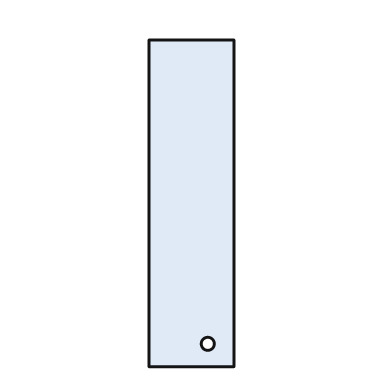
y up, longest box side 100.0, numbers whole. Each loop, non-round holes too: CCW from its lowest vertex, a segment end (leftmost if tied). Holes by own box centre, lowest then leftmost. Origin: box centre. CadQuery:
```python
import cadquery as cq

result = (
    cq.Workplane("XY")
    .moveTo(-13.0, -50.0)
    .lineTo(13.0, -50.0)
    .lineTo(13.0, 50.0)
    .lineTo(-13.0, 50.0)
    .close()
    .moveTo(5.0, -43.0)
    .circle(2.0)
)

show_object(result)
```